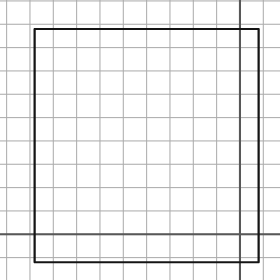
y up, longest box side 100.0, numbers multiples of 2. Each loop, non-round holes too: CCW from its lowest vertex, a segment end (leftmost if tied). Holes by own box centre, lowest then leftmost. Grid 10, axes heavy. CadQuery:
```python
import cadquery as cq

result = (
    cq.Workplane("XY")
    .moveTo(-88.0, -12.0)
    .lineTo(8.0, -12.0)
    .lineTo(8.0, 88.0)
    .lineTo(-88.0, 88.0)
    .close()
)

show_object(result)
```